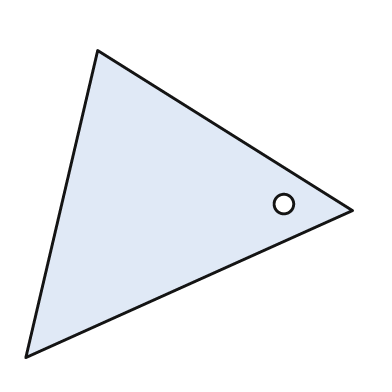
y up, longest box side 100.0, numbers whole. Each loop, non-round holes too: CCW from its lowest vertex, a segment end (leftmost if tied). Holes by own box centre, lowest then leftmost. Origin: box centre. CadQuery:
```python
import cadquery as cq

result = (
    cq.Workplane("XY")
    .moveTo(-50.0, -47.0)
    .lineTo(50.0, -2.0)
    .lineTo(-28.0, 47.0)
    .close()
    .moveTo(29.0, 0.0)
    .circle(3.0)
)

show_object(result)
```